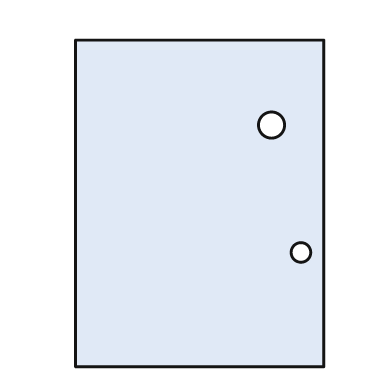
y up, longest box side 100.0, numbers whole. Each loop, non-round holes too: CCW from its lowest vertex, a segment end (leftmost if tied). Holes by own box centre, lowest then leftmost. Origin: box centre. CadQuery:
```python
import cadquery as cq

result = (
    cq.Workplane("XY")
    .moveTo(-38.0, -50.0)
    .lineTo(38.0, -50.0)
    .lineTo(38.0, 50.0)
    .lineTo(-38.0, 50.0)
    .close()
    .moveTo(31.0, -15.0)
    .circle(3.0)
    .moveTo(22.0, 24.0)
    .circle(4.0)
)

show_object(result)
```